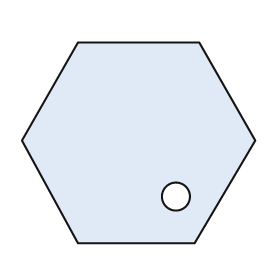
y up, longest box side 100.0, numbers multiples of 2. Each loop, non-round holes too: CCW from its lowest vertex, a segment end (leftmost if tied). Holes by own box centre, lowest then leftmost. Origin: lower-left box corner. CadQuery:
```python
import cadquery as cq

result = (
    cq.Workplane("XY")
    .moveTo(24.0, 0.0)
    .lineTo(74.0, 0.0)
    .lineTo(100.0, 44.0)
    .lineTo(76.0, 86.0)
    .lineTo(24.0, 86.0)
    .lineTo(0.0, 44.0)
    .close()
    .moveTo(66.0, 20.0)
    .circle(6.0)
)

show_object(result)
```